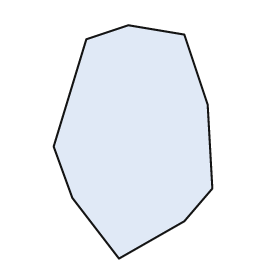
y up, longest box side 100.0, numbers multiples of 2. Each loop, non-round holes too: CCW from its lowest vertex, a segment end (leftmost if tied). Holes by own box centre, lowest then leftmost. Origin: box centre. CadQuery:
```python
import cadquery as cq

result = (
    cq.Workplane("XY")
    .moveTo(-6.0, -50.0)
    .lineTo(22.0, -34.0)
    .lineTo(34.0, -20.0)
    .lineTo(32.0, 16.0)
    .lineTo(22.0, 46.0)
    .lineTo(-2.0, 50.0)
    .lineTo(-20.0, 44.0)
    .lineTo(-34.0, -2.0)
    .lineTo(-26.0, -24.0)
    .close()
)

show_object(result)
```